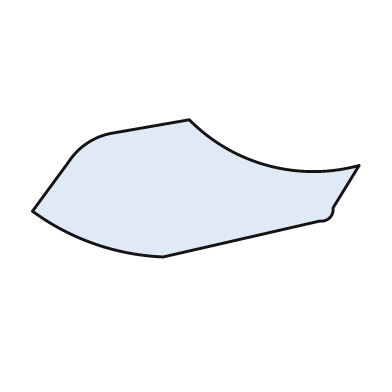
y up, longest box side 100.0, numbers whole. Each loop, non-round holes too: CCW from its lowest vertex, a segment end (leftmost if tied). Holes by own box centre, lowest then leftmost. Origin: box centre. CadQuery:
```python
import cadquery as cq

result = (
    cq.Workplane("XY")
    .moveTo(-10.0, -21.0)
    .lineTo(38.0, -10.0)
    .threePointArc((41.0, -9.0), (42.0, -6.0))
    .lineTo(50.0, 7.0)
    .threePointArc((22.0, 7.0), (-2.0, 21.0))
    .lineTo(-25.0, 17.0)
    .threePointArc((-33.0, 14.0), (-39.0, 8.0))
    .lineTo(-50.0, -7.0)
    .threePointArc((-31.0, -17.0), (-10.0, -21.0))
    .close()
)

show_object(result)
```